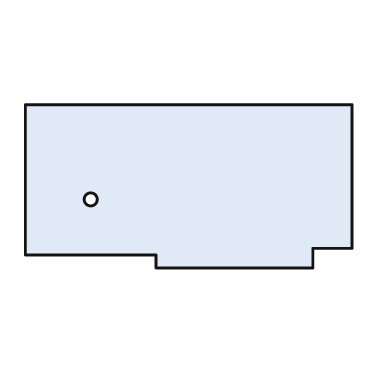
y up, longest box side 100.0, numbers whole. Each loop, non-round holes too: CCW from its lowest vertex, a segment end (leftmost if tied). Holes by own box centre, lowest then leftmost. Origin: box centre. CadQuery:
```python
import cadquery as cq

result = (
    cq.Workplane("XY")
    .moveTo(-10.0, -25.0)
    .lineTo(38.0, -25.0)
    .lineTo(38.0, -19.0)
    .lineTo(50.0, -19.0)
    .lineTo(50.0, 25.0)
    .lineTo(-50.0, 25.0)
    .lineTo(-50.0, -21.0)
    .lineTo(-10.0, -21.0)
    .close()
    .moveTo(-30.0, -4.0)
    .circle(2.0)
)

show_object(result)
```